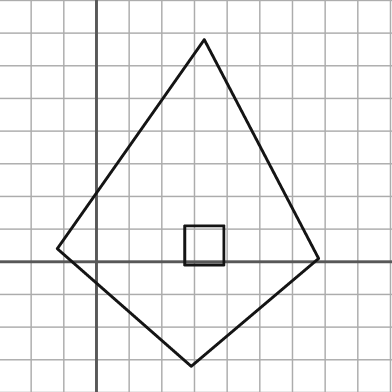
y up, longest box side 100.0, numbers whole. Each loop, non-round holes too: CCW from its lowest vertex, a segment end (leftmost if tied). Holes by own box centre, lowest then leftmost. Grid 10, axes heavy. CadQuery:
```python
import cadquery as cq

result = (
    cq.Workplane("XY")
    .moveTo(29.0, -32.0)
    .lineTo(68.0, 1.0)
    .lineTo(33.0, 68.0)
    .lineTo(-12.0, 4.0)
    .close()
    .moveTo(27.0, -1.0)
    .lineTo(39.0, -1.0)
    .lineTo(39.0, 11.0)
    .lineTo(27.0, 11.0)
    .close()
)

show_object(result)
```